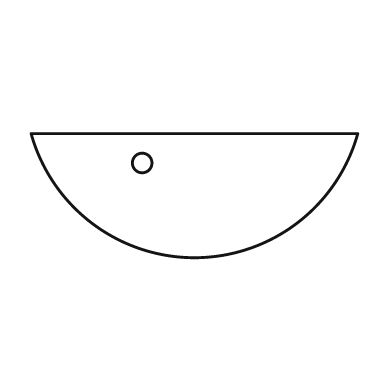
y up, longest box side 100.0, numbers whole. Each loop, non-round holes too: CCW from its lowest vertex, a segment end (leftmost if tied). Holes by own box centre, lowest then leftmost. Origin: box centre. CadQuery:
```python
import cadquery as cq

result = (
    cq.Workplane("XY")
    .moveTo(-50.0, 19.0)
    .threePointArc((0.0, -19.0), (50.0, 19.0))
    .close()
    .moveTo(-16.0, 10.0)
    .circle(3.0)
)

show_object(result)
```